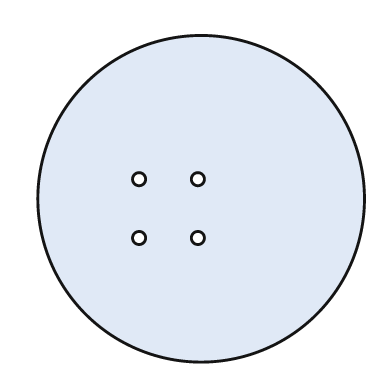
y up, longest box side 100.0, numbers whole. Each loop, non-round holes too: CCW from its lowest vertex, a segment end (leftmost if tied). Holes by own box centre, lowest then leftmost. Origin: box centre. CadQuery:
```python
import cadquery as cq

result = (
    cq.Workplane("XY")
    .moveTo(0.0, 0.0)
    .circle(50.0)
    .moveTo(-19.0, -12.0)
    .circle(2.0)
    .moveTo(-1.0, -12.0)
    .circle(2.0)
    .moveTo(-19.0, 6.0)
    .circle(2.0)
    .moveTo(-1.0, 6.0)
    .circle(2.0)
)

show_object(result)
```